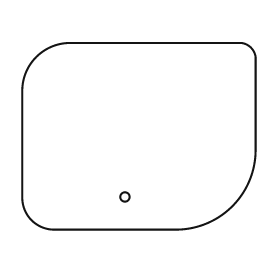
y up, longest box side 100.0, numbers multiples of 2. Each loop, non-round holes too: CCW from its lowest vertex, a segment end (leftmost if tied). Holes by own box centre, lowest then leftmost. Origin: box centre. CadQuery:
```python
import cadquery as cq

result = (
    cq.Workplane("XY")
    .moveTo(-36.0, -40.0)
    .lineTo(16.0, -40.0)
    .threePointArc((40.0, -30.0), (50.0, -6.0))
    .lineTo(50.0, 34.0)
    .threePointArc((48.0, 38.0), (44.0, 40.0))
    .lineTo(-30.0, 40.0)
    .threePointArc((-44.0, 34.0), (-50.0, 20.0))
    .lineTo(-50.0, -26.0)
    .threePointArc((-46.0, -36.0), (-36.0, -40.0))
    .close()
    .moveTo(-6.0, -26.0)
    .circle(2.0)
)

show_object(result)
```